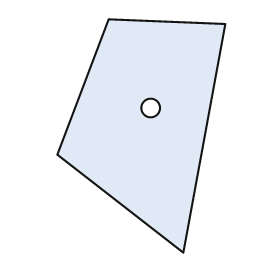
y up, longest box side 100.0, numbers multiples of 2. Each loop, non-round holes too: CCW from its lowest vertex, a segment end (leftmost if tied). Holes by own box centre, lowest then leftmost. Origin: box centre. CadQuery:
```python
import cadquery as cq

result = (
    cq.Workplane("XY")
    .moveTo(18.0, -50.0)
    .lineTo(36.0, 48.0)
    .lineTo(-14.0, 50.0)
    .lineTo(-36.0, -8.0)
    .close()
    .moveTo(4.0, 12.0)
    .circle(4.0)
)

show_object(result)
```